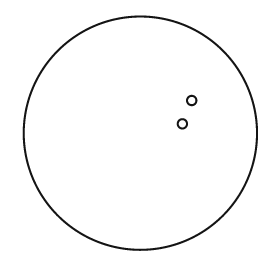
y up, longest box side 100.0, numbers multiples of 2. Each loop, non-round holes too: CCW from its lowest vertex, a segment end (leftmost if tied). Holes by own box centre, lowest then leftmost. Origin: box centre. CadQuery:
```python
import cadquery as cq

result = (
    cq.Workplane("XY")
    .moveTo(0.0, 0.0)
    .circle(50.0)
    .moveTo(18.0, 4.0)
    .circle(2.0)
    .moveTo(22.0, 14.0)
    .circle(2.0)
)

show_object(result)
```